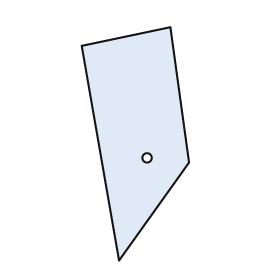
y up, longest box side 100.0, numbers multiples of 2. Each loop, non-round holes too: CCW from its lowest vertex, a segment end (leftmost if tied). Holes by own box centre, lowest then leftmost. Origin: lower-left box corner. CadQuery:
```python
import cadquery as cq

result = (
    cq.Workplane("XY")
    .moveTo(16.0, 0.0)
    .lineTo(46.0, 42.0)
    .lineTo(38.0, 100.0)
    .lineTo(0.0, 92.0)
    .close()
    .moveTo(28.0, 44.0)
    .circle(2.0)
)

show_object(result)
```